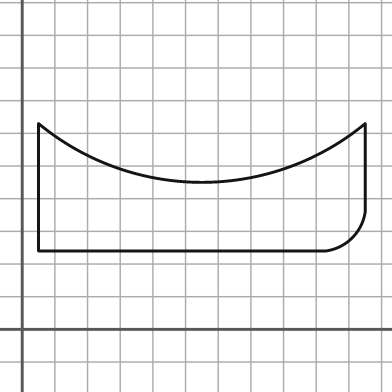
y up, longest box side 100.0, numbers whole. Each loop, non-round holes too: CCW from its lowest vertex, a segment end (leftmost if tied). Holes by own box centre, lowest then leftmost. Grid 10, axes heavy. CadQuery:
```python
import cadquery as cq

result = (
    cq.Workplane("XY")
    .moveTo(5.0, 24.0)
    .lineTo(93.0, 24.0)
    .threePointArc((101.0, 28.0), (105.0, 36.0))
    .lineTo(105.0, 63.0)
    .threePointArc((55.0, 45.0), (5.0, 63.0))
    .close()
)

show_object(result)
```